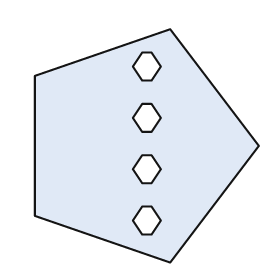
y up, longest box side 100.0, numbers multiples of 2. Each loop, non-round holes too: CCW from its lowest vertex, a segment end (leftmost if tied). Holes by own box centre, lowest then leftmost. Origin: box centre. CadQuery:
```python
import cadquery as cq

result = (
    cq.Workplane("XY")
    .moveTo(10.0, -50.0)
    .lineTo(48.0, 0.0)
    .lineTo(10.0, 50.0)
    .lineTo(-48.0, 30.0)
    .lineTo(-48.0, -30.0)
    .close()
    .moveTo(-2.0, -38.0)
    .lineTo(2.0, -38.0)
    .lineTo(6.0, -32.0)
    .lineTo(2.0, -26.0)
    .lineTo(-2.0, -26.0)
    .lineTo(-6.0, -32.0)
    .close()
    .moveTo(-2.0, -16.0)
    .lineTo(2.0, -16.0)
    .lineTo(6.0, -10.0)
    .lineTo(2.0, -4.0)
    .lineTo(-2.0, -4.0)
    .lineTo(-6.0, -10.0)
    .close()
    .moveTo(-2.0, 6.0)
    .lineTo(2.0, 6.0)
    .lineTo(6.0, 12.0)
    .lineTo(2.0, 18.0)
    .lineTo(-2.0, 18.0)
    .lineTo(-6.0, 12.0)
    .close()
    .moveTo(-2.0, 28.0)
    .lineTo(2.0, 28.0)
    .lineTo(6.0, 34.0)
    .lineTo(2.0, 40.0)
    .lineTo(-2.0, 40.0)
    .lineTo(-6.0, 34.0)
    .close()
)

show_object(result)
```